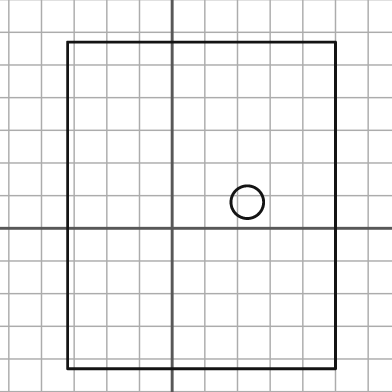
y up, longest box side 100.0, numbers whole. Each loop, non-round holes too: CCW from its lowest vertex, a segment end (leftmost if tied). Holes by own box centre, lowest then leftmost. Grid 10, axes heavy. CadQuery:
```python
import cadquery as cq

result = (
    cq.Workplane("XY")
    .moveTo(-32.0, -43.0)
    .lineTo(50.0, -43.0)
    .lineTo(50.0, 57.0)
    .lineTo(-32.0, 57.0)
    .close()
    .moveTo(23.0, 8.0)
    .circle(5.0)
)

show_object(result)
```